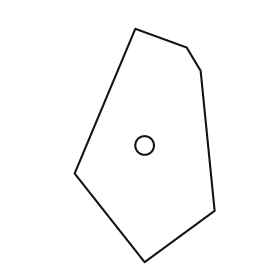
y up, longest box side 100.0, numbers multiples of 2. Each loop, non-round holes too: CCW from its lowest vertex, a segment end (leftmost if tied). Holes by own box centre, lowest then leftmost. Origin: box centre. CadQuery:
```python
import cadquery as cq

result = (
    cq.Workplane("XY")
    .moveTo(0.0, -50.0)
    .lineTo(30.0, -28.0)
    .lineTo(24.0, 32.0)
    .lineTo(18.0, 42.0)
    .lineTo(-4.0, 50.0)
    .lineTo(-30.0, -12.0)
    .close()
    .moveTo(0.0, 0.0)
    .circle(4.0)
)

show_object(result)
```